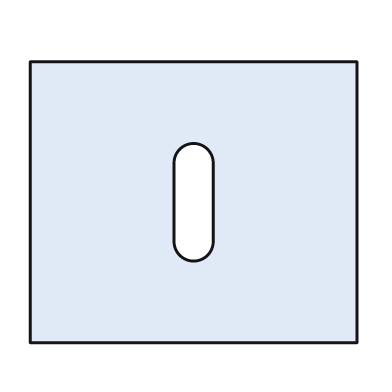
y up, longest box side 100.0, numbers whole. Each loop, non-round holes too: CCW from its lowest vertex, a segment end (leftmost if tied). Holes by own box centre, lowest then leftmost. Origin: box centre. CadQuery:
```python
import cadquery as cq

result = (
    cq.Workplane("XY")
    .moveTo(-50.0, -43.0)
    .lineTo(50.0, -43.0)
    .lineTo(50.0, 43.0)
    .lineTo(-50.0, 43.0)
    .close()
    .moveTo(-6.0, -12.0)
    .threePointArc((0.0, -18.0), (6.0, -12.0))
    .lineTo(6.0, 12.0)
    .threePointArc((0.0, 18.0), (-6.0, 12.0))
    .close()
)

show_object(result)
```